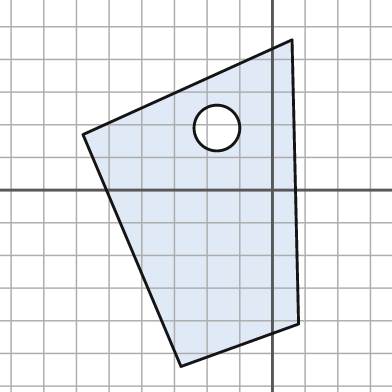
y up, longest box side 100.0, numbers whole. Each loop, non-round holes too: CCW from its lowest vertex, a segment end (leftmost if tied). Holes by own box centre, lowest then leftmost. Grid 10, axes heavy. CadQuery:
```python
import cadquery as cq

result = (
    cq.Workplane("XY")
    .moveTo(-28.0, -54.0)
    .lineTo(8.0, -41.0)
    .lineTo(6.0, 46.0)
    .lineTo(-58.0, 17.0)
    .close()
    .moveTo(-17.0, 19.0)
    .circle(7.0)
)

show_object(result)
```